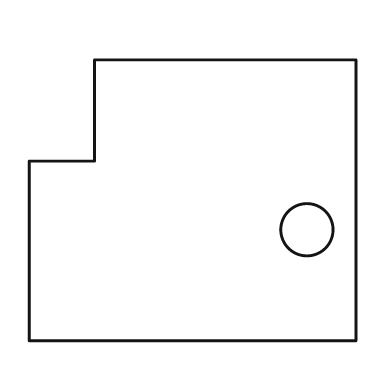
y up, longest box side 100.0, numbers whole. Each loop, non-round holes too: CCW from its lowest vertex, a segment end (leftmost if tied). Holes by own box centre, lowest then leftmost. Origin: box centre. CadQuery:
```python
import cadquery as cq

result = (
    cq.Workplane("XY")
    .moveTo(-50.0, -43.0)
    .lineTo(50.0, -43.0)
    .lineTo(50.0, 43.0)
    .lineTo(-30.0, 43.0)
    .lineTo(-30.0, 12.0)
    .lineTo(-50.0, 12.0)
    .close()
    .moveTo(35.0, -9.0)
    .circle(8.0)
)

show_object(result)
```